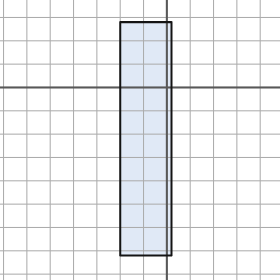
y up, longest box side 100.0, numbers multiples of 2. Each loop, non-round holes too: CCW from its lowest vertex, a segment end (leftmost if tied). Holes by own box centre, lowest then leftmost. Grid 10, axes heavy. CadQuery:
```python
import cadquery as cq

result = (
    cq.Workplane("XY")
    .moveTo(-20.0, -72.0)
    .lineTo(2.0, -72.0)
    .lineTo(2.0, 28.0)
    .lineTo(-20.0, 28.0)
    .close()
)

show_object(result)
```